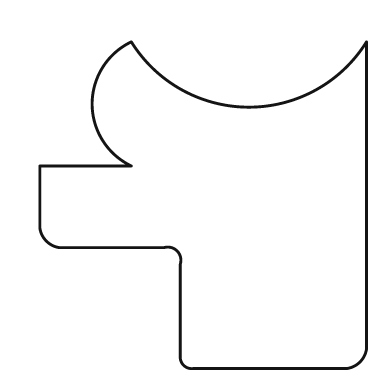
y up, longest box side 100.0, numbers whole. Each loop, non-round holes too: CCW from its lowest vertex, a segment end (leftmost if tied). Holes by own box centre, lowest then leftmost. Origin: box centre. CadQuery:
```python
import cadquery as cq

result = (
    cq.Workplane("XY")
    .moveTo(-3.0, -50.0)
    .lineTo(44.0, -50.0)
    .threePointArc((48.0, -48.0), (50.0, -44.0))
    .lineTo(50.0, 50.0)
    .threePointArc((14.0, 30.0), (-22.0, 50.0))
    .threePointArc((-34.0, 31.0), (-22.0, 12.0))
    .lineTo(-50.0, 12.0)
    .lineTo(-50.0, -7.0)
    .threePointArc((-48.0, -11.0), (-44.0, -13.0))
    .lineTo(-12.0, -13.0)
    .threePointArc((-8.0, -14.0), (-7.0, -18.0))
    .lineTo(-7.0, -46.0)
    .threePointArc((-6.0, -49.0), (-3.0, -50.0))
    .close()
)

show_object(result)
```